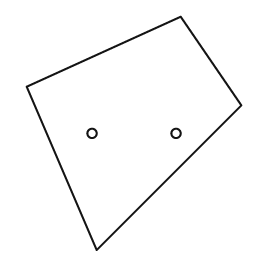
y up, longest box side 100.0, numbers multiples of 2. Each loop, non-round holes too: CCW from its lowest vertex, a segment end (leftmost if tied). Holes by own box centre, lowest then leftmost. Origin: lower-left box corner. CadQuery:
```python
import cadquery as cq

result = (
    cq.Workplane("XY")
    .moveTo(30.0, 0.0)
    .lineTo(92.0, 62.0)
    .lineTo(66.0, 100.0)
    .lineTo(0.0, 70.0)
    .close()
    .moveTo(28.0, 50.0)
    .circle(2.0)
    .moveTo(64.0, 50.0)
    .circle(2.0)
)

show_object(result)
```